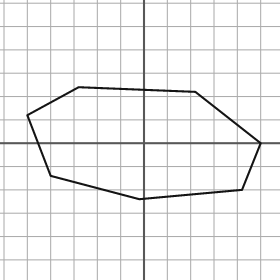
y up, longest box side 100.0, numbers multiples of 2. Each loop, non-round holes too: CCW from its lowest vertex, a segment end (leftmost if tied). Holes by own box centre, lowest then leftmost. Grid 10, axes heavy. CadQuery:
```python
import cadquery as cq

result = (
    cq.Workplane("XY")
    .moveTo(-2.0, -24.0)
    .lineTo(42.0, -20.0)
    .lineTo(50.0, 0.0)
    .lineTo(22.0, 22.0)
    .lineTo(-28.0, 24.0)
    .lineTo(-50.0, 12.0)
    .lineTo(-40.0, -14.0)
    .close()
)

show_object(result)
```